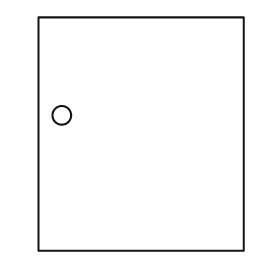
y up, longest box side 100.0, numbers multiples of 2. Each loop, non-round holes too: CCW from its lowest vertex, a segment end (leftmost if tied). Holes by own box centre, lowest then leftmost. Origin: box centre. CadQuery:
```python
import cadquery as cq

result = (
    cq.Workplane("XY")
    .moveTo(-44.0, -50.0)
    .lineTo(44.0, -50.0)
    .lineTo(44.0, 50.0)
    .lineTo(-44.0, 50.0)
    .close()
    .moveTo(-34.0, 8.0)
    .circle(4.0)
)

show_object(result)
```